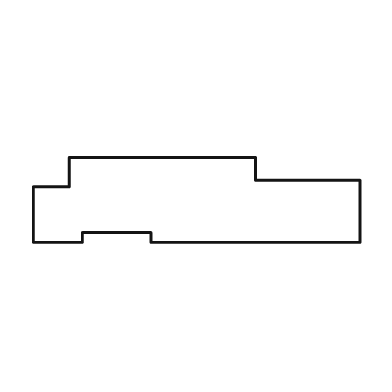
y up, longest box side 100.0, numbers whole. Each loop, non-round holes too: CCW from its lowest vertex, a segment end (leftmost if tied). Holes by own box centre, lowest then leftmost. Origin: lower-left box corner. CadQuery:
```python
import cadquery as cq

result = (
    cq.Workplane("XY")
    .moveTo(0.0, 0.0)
    .lineTo(15.0, 0.0)
    .lineTo(15.0, 3.0)
    .lineTo(36.0, 3.0)
    .lineTo(36.0, 0.0)
    .lineTo(100.0, 0.0)
    .lineTo(100.0, 19.0)
    .lineTo(68.0, 19.0)
    .lineTo(68.0, 26.0)
    .lineTo(11.0, 26.0)
    .lineTo(11.0, 17.0)
    .lineTo(0.0, 17.0)
    .close()
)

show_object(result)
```